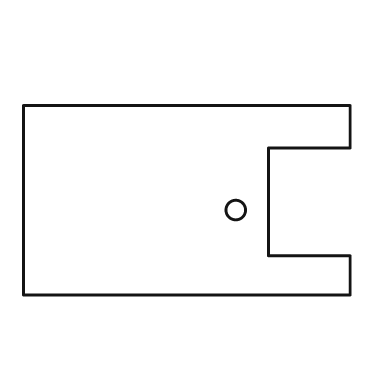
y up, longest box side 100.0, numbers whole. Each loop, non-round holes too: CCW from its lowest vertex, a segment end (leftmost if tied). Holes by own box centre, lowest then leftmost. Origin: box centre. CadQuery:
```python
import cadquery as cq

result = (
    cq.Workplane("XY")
    .moveTo(-50.0, -29.0)
    .lineTo(50.0, -29.0)
    .lineTo(50.0, -17.0)
    .lineTo(25.0, -17.0)
    .lineTo(25.0, 16.0)
    .lineTo(50.0, 16.0)
    .lineTo(50.0, 29.0)
    .lineTo(-50.0, 29.0)
    .close()
    .moveTo(15.0, -3.0)
    .circle(3.0)
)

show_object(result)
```